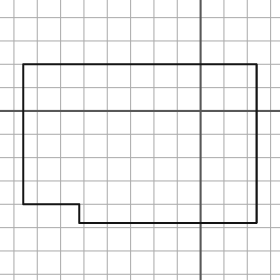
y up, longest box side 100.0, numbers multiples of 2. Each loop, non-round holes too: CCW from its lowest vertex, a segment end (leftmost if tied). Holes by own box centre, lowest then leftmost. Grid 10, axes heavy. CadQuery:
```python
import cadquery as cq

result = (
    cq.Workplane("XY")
    .moveTo(-52.0, -48.0)
    .lineTo(24.0, -48.0)
    .lineTo(24.0, 20.0)
    .lineTo(-76.0, 20.0)
    .lineTo(-76.0, -40.0)
    .lineTo(-52.0, -40.0)
    .close()
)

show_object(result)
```